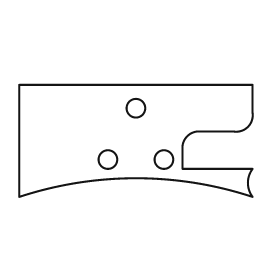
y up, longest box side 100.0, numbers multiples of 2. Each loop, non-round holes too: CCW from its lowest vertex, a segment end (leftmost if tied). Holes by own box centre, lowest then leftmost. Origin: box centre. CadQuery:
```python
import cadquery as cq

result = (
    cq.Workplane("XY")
    .moveTo(-50.0, -24.0)
    .threePointArc((0.0, -16.0), (50.0, -24.0))
    .threePointArc((48.0, -18.0), (50.0, -12.0))
    .lineTo(20.0, -12.0)
    .lineTo(20.0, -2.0)
    .threePointArc((22.0, 2.0), (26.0, 4.0))
    .lineTo(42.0, 4.0)
    .threePointArc((48.0, 6.0), (50.0, 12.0))
    .lineTo(50.0, 24.0)
    .lineTo(-50.0, 24.0)
    .close()
    .moveTo(-12.0, -8.0)
    .circle(4.0)
    .moveTo(12.0, -8.0)
    .circle(4.0)
    .moveTo(0.0, 14.0)
    .circle(4.0)
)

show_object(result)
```